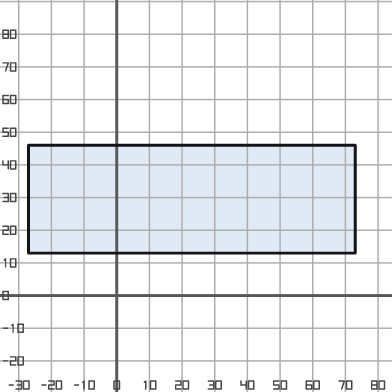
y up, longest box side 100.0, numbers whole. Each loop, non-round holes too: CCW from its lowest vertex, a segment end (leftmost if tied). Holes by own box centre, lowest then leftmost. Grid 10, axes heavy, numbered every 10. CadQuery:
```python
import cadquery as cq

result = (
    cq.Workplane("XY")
    .moveTo(-27.0, 13.0)
    .lineTo(73.0, 13.0)
    .lineTo(73.0, 46.0)
    .lineTo(-27.0, 46.0)
    .close()
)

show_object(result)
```